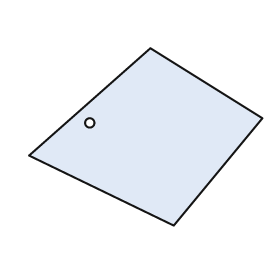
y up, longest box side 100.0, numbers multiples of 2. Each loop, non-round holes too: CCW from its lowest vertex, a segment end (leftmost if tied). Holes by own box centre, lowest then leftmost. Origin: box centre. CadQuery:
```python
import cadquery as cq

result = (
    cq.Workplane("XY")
    .moveTo(12.0, -38.0)
    .lineTo(50.0, 8.0)
    .lineTo(2.0, 38.0)
    .lineTo(-50.0, -8.0)
    .close()
    .moveTo(-24.0, 6.0)
    .circle(2.0)
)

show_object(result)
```